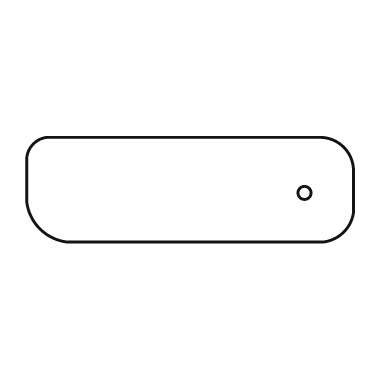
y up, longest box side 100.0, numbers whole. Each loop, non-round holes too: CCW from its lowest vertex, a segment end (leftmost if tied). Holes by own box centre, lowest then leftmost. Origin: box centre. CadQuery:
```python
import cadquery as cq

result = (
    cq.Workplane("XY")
    .moveTo(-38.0, -16.0)
    .lineTo(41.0, -16.0)
    .threePointArc((47.0, -13.0), (50.0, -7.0))
    .lineTo(50.0, 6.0)
    .threePointArc((47.0, 13.0), (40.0, 16.0))
    .lineTo(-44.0, 16.0)
    .threePointArc((-48.0, 14.0), (-50.0, 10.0))
    .lineTo(-50.0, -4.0)
    .threePointArc((-46.0, -12.0), (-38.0, -16.0))
    .close()
    .moveTo(35.0, -1.0)
    .circle(2.0)
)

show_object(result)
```